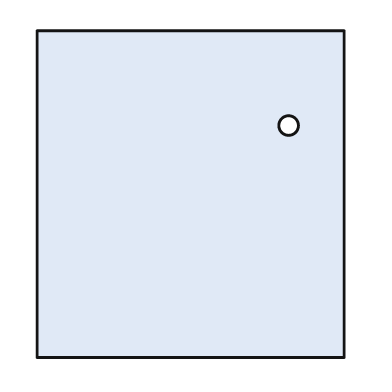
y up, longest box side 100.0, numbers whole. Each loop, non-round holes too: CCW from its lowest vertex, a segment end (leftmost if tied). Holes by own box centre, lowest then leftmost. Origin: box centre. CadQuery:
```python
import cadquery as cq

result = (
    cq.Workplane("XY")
    .moveTo(-47.0, -50.0)
    .lineTo(47.0, -50.0)
    .lineTo(47.0, 50.0)
    .lineTo(-47.0, 50.0)
    .close()
    .moveTo(30.0, 21.0)
    .circle(3.0)
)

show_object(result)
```